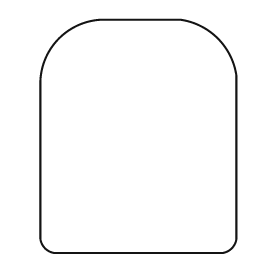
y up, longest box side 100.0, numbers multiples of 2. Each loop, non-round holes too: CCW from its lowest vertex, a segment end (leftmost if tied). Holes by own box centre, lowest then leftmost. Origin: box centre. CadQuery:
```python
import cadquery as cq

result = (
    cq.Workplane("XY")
    .moveTo(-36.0, -50.0)
    .lineTo(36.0, -50.0)
    .threePointArc((40.0, -48.0), (42.0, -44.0))
    .lineTo(42.0, 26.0)
    .threePointArc((34.0, 42.0), (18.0, 50.0))
    .lineTo(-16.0, 50.0)
    .threePointArc((-34.0, 42.0), (-42.0, 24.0))
    .lineTo(-42.0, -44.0)
    .threePointArc((-40.0, -48.0), (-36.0, -50.0))
    .close()
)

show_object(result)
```